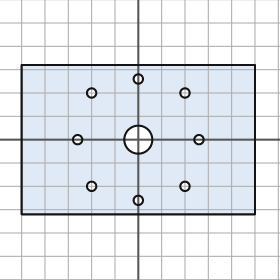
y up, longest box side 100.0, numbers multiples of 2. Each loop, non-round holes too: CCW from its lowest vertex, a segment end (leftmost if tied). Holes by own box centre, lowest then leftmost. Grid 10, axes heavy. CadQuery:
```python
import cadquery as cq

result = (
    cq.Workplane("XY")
    .moveTo(-50.0, -32.0)
    .lineTo(50.0, -32.0)
    .lineTo(50.0, 32.0)
    .lineTo(-50.0, 32.0)
    .close()
    .moveTo(0.0, -26.0)
    .circle(2.0)
    .moveTo(-20.0, -20.0)
    .circle(2.0)
    .moveTo(20.0, -20.0)
    .circle(2.0)
    .moveTo(-26.0, 0.0)
    .circle(2.0)
    .moveTo(0.0, 0.0)
    .circle(6.0)
    .moveTo(26.0, 0.0)
    .circle(2.0)
    .moveTo(-20.0, 20.0)
    .circle(2.0)
    .moveTo(20.0, 20.0)
    .circle(2.0)
    .moveTo(0.0, 26.0)
    .circle(2.0)
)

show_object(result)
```